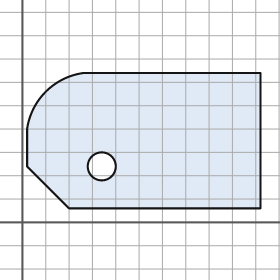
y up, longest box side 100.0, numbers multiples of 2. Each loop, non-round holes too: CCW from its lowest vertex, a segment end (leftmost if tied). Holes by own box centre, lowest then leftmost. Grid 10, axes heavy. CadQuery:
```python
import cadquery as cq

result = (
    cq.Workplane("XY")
    .moveTo(20.0, 6.0)
    .lineTo(102.0, 6.0)
    .lineTo(102.0, 64.0)
    .lineTo(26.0, 64.0)
    .threePointArc((10.0, 56.0), (2.0, 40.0))
    .lineTo(2.0, 24.0)
    .close()
    .moveTo(34.0, 24.0)
    .circle(6.0)
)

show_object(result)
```